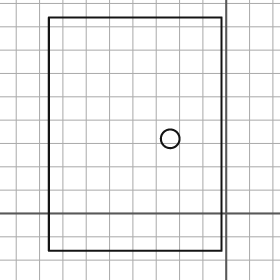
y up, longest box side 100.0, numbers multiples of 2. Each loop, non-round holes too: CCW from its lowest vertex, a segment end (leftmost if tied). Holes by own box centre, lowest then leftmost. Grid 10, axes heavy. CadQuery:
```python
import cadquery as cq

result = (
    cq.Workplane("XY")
    .moveTo(-76.0, -16.0)
    .lineTo(-2.0, -16.0)
    .lineTo(-2.0, 84.0)
    .lineTo(-76.0, 84.0)
    .close()
    .moveTo(-24.0, 32.0)
    .circle(4.0)
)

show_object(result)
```